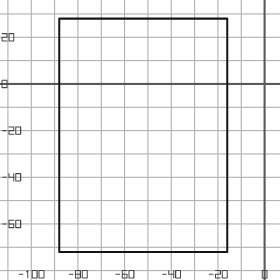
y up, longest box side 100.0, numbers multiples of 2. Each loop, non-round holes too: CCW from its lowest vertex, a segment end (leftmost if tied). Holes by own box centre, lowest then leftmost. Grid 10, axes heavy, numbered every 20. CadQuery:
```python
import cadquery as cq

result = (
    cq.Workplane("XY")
    .moveTo(-88.0, -72.0)
    .lineTo(-16.0, -72.0)
    .lineTo(-16.0, 28.0)
    .lineTo(-88.0, 28.0)
    .close()
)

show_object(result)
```